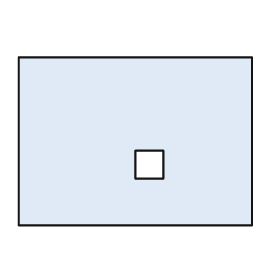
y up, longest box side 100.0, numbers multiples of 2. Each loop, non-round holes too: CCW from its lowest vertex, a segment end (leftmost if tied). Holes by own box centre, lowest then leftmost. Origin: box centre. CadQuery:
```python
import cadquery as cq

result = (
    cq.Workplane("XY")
    .moveTo(-50.0, -36.0)
    .lineTo(50.0, -36.0)
    .lineTo(50.0, 36.0)
    .lineTo(-50.0, 36.0)
    .close()
    .moveTo(0.0, -16.0)
    .lineTo(12.0, -16.0)
    .lineTo(12.0, -4.0)
    .lineTo(0.0, -4.0)
    .close()
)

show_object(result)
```